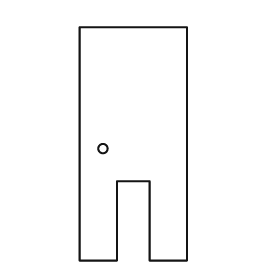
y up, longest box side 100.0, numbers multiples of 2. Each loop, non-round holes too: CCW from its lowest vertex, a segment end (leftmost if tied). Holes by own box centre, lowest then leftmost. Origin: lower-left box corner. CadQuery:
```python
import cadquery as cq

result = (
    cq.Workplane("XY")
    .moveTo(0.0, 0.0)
    .lineTo(16.0, 0.0)
    .lineTo(16.0, 34.0)
    .lineTo(30.0, 34.0)
    .lineTo(30.0, 0.0)
    .lineTo(46.0, 0.0)
    .lineTo(46.0, 100.0)
    .lineTo(0.0, 100.0)
    .close()
    .moveTo(10.0, 48.0)
    .circle(2.0)
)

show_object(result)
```